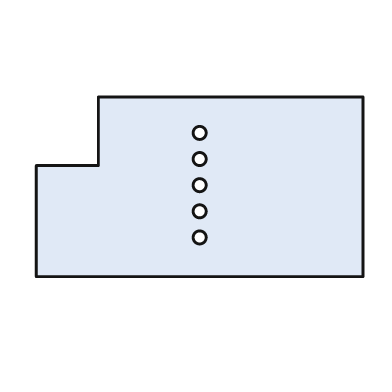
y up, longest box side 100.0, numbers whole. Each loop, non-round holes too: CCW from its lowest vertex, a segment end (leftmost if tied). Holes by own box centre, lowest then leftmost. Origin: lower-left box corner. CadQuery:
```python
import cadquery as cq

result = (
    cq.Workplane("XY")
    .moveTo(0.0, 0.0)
    .lineTo(100.0, 0.0)
    .lineTo(100.0, 55.0)
    .lineTo(19.0, 55.0)
    .lineTo(19.0, 34.0)
    .lineTo(0.0, 34.0)
    .close()
    .moveTo(50.0, 12.0)
    .circle(2.0)
    .moveTo(50.0, 20.0)
    .circle(2.0)
    .moveTo(50.0, 28.0)
    .circle(2.0)
    .moveTo(50.0, 36.0)
    .circle(2.0)
    .moveTo(50.0, 44.0)
    .circle(2.0)
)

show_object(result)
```